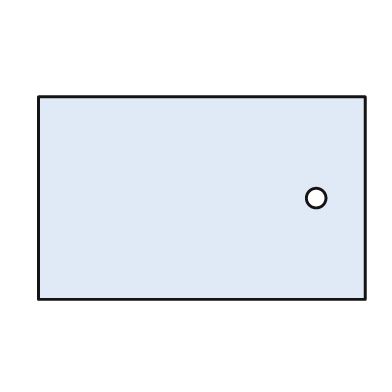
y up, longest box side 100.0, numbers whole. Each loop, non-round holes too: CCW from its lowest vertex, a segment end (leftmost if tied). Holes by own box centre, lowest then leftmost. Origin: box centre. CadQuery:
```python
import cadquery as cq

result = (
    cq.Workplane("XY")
    .moveTo(-50.0, -31.0)
    .lineTo(50.0, -31.0)
    .lineTo(50.0, 31.0)
    .lineTo(-50.0, 31.0)
    .close()
    .moveTo(35.0, 0.0)
    .circle(3.0)
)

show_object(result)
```